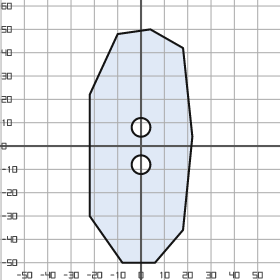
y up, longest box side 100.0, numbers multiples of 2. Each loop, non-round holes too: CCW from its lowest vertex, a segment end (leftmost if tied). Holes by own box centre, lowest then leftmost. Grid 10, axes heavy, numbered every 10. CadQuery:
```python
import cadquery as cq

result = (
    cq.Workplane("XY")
    .moveTo(-8.0, -50.0)
    .lineTo(6.0, -50.0)
    .lineTo(18.0, -36.0)
    .lineTo(22.0, 4.0)
    .lineTo(18.0, 42.0)
    .lineTo(4.0, 50.0)
    .lineTo(-10.0, 48.0)
    .lineTo(-22.0, 22.0)
    .lineTo(-22.0, -30.0)
    .close()
    .moveTo(0.0, -8.0)
    .circle(4.0)
    .moveTo(0.0, 8.0)
    .circle(4.0)
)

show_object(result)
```